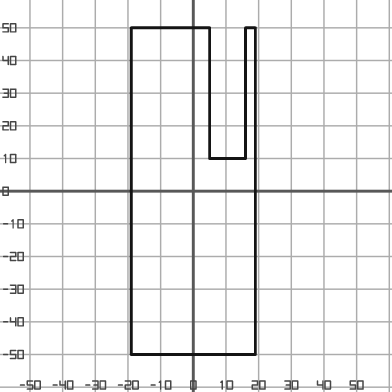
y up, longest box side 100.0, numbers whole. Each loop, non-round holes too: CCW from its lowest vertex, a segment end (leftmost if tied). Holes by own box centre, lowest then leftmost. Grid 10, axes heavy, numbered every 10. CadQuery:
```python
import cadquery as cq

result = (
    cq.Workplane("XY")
    .moveTo(-19.0, -50.0)
    .lineTo(19.0, -50.0)
    .lineTo(19.0, 50.0)
    .lineTo(16.0, 50.0)
    .lineTo(16.0, 10.0)
    .lineTo(5.0, 10.0)
    .lineTo(5.0, 50.0)
    .lineTo(-19.0, 50.0)
    .close()
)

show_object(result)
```